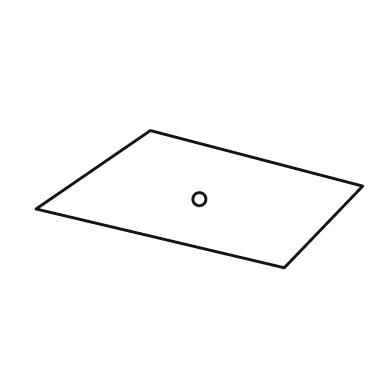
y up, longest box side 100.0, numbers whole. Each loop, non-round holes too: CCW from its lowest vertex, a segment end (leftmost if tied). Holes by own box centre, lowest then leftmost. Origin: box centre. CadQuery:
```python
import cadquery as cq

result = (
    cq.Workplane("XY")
    .moveTo(26.0, -21.0)
    .lineTo(50.0, 4.0)
    .lineTo(-15.0, 21.0)
    .lineTo(-50.0, -3.0)
    .close()
    .moveTo(0.0, 0.0)
    .circle(2.0)
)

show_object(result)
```